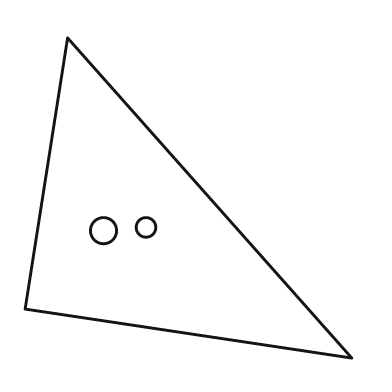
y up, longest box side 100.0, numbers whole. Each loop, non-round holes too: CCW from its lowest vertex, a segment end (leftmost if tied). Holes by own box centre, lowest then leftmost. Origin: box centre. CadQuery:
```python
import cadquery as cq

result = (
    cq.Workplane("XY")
    .moveTo(50.0, -49.0)
    .lineTo(-37.0, 49.0)
    .lineTo(-50.0, -34.0)
    .close()
    .moveTo(-26.0, -10.0)
    .circle(4.0)
    .moveTo(-13.0, -9.0)
    .circle(3.0)
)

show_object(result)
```